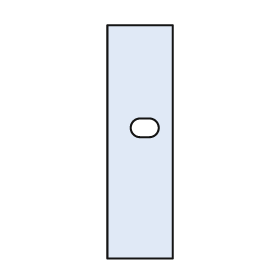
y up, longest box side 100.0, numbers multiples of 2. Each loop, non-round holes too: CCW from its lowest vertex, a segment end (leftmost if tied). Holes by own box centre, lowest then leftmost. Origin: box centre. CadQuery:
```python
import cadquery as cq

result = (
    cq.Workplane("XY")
    .moveTo(-14.0, -50.0)
    .lineTo(14.0, -50.0)
    .lineTo(14.0, 50.0)
    .lineTo(-14.0, 50.0)
    .close()
    .moveTo(0.0, 2.0)
    .lineTo(4.0, 2.0)
    .threePointArc((8.0, 6.0), (4.0, 10.0))
    .lineTo(0.0, 10.0)
    .threePointArc((-4.0, 6.0), (0.0, 2.0))
    .close()
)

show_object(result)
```